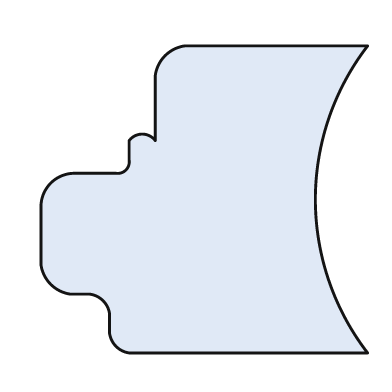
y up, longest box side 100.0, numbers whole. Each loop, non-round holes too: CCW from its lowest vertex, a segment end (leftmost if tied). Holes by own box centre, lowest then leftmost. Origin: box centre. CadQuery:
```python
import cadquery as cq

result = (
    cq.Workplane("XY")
    .moveTo(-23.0, -47.0)
    .lineTo(50.0, -47.0)
    .threePointArc((34.0, 0.0), (50.0, 47.0))
    .lineTo(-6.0, 47.0)
    .threePointArc((-12.0, 44.0), (-15.0, 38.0))
    .lineTo(-15.0, 18.0)
    .threePointArc((-19.0, 20.0), (-23.0, 18.0))
    .lineTo(-23.0, 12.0)
    .threePointArc((-24.0, 9.0), (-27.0, 8.0))
    .lineTo(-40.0, 8.0)
    .threePointArc((-47.0, 5.0), (-50.0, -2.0))
    .lineTo(-50.0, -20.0)
    .threePointArc((-47.0, -26.0), (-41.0, -29.0))
    .lineTo(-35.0, -29.0)
    .threePointArc((-31.0, -31.0), (-29.0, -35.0))
    .lineTo(-29.0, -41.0)
    .threePointArc((-27.0, -45.0), (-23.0, -47.0))
    .close()
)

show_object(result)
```